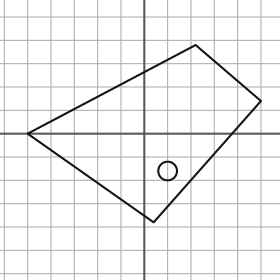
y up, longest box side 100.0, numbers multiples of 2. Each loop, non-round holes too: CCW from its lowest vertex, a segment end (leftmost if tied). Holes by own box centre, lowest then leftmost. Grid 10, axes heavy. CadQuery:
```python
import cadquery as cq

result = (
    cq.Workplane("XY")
    .moveTo(4.0, -38.0)
    .lineTo(50.0, 14.0)
    .lineTo(22.0, 38.0)
    .lineTo(-50.0, 0.0)
    .close()
    .moveTo(10.0, -16.0)
    .circle(4.0)
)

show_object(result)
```